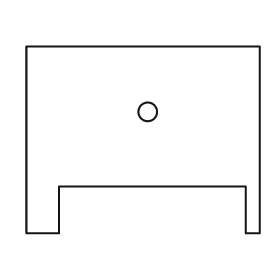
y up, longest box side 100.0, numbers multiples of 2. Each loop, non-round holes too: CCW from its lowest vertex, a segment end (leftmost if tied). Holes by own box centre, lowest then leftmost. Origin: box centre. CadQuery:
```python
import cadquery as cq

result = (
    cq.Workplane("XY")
    .moveTo(-50.0, -40.0)
    .lineTo(-36.0, -40.0)
    .lineTo(-36.0, -20.0)
    .lineTo(44.0, -20.0)
    .lineTo(44.0, -40.0)
    .lineTo(50.0, -40.0)
    .lineTo(50.0, 40.0)
    .lineTo(-50.0, 40.0)
    .close()
    .moveTo(2.0, 12.0)
    .circle(4.0)
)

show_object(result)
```